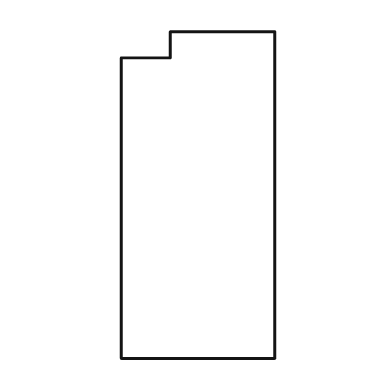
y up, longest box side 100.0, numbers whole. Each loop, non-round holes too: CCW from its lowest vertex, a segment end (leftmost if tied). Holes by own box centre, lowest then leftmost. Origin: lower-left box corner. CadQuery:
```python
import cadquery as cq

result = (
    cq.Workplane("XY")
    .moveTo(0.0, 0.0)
    .lineTo(47.0, 0.0)
    .lineTo(47.0, 100.0)
    .lineTo(15.0, 100.0)
    .lineTo(15.0, 92.0)
    .lineTo(0.0, 92.0)
    .close()
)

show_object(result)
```